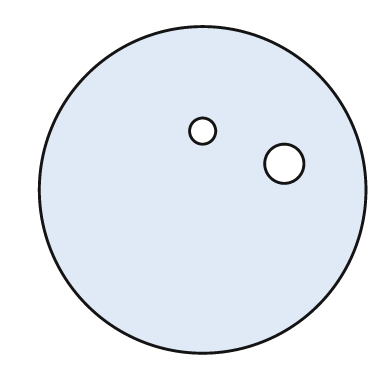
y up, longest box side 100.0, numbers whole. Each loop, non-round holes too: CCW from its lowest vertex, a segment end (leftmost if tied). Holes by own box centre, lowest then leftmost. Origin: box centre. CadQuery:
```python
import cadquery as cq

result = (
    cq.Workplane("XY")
    .moveTo(0.0, 0.0)
    .circle(50.0)
    .moveTo(25.0, 8.0)
    .circle(6.0)
    .moveTo(0.0, 18.0)
    .circle(4.0)
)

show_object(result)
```